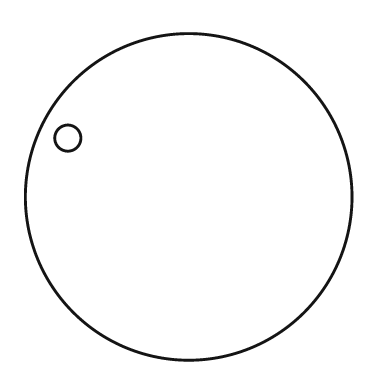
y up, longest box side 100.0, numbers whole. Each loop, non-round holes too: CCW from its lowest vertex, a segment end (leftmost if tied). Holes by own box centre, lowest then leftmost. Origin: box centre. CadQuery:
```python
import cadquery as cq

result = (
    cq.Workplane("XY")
    .moveTo(0.0, 0.0)
    .circle(50.0)
    .moveTo(-37.0, 18.0)
    .circle(4.0)
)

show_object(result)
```